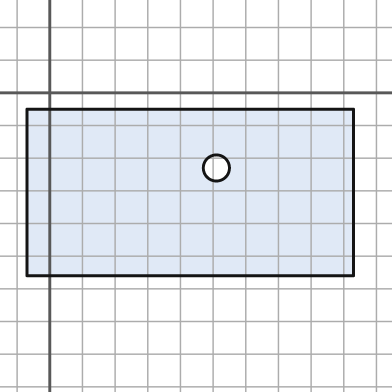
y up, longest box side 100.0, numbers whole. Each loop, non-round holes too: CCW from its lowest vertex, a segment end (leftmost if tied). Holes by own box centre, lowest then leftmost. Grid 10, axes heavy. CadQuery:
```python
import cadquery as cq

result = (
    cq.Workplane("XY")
    .moveTo(-7.0, -56.0)
    .lineTo(93.0, -56.0)
    .lineTo(93.0, -5.0)
    .lineTo(-7.0, -5.0)
    .close()
    .moveTo(51.0, -23.0)
    .circle(4.0)
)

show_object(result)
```